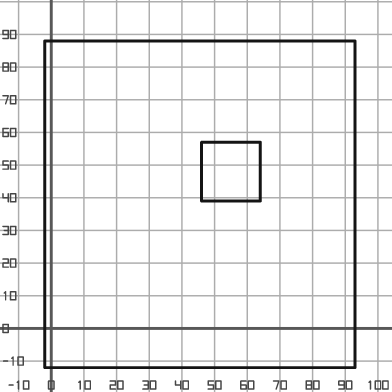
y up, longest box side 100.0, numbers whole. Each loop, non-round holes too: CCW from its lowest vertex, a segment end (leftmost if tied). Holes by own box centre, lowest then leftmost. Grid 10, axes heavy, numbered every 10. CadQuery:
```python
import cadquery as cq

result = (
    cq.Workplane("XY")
    .moveTo(-2.0, -12.0)
    .lineTo(93.0, -12.0)
    .lineTo(93.0, 88.0)
    .lineTo(-2.0, 88.0)
    .close()
    .moveTo(46.0, 39.0)
    .lineTo(64.0, 39.0)
    .lineTo(64.0, 57.0)
    .lineTo(46.0, 57.0)
    .close()
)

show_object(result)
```